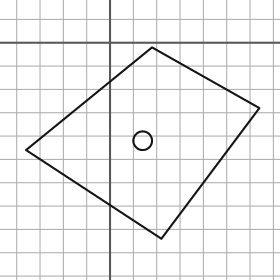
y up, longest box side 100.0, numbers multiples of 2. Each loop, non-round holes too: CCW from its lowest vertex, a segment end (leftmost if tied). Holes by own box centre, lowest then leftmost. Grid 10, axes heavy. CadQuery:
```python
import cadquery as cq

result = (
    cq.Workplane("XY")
    .moveTo(22.0, -84.0)
    .lineTo(64.0, -28.0)
    .lineTo(18.0, -2.0)
    .lineTo(-36.0, -46.0)
    .close()
    .moveTo(14.0, -42.0)
    .circle(4.0)
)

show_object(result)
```